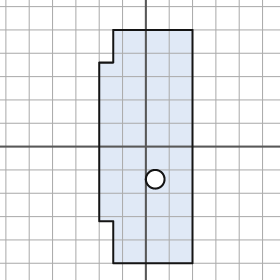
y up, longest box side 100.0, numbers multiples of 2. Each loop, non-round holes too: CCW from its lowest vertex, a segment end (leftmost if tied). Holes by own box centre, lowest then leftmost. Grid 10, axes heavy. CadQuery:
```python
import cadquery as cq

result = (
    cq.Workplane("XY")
    .moveTo(-14.0, -50.0)
    .lineTo(20.0, -50.0)
    .lineTo(20.0, 50.0)
    .lineTo(-14.0, 50.0)
    .lineTo(-14.0, 36.0)
    .lineTo(-20.0, 36.0)
    .lineTo(-20.0, -32.0)
    .lineTo(-14.0, -32.0)
    .close()
    .moveTo(4.0, -14.0)
    .circle(4.0)
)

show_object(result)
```